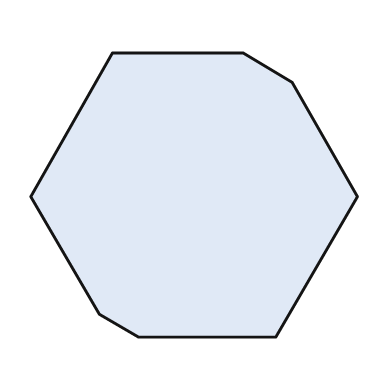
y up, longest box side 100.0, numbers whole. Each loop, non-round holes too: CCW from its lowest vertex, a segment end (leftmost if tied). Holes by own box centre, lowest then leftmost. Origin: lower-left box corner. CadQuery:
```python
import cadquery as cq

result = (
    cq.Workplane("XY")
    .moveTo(33.0, 0.0)
    .lineTo(75.0, 0.0)
    .lineTo(100.0, 43.0)
    .lineTo(80.0, 78.0)
    .lineTo(65.0, 87.0)
    .lineTo(25.0, 87.0)
    .lineTo(0.0, 43.0)
    .lineTo(21.0, 7.0)
    .close()
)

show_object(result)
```